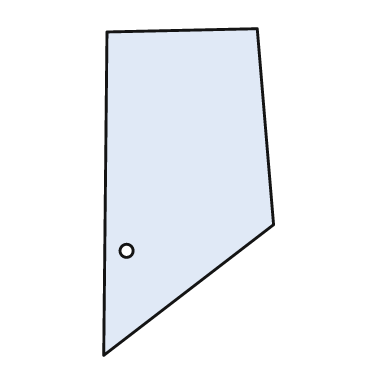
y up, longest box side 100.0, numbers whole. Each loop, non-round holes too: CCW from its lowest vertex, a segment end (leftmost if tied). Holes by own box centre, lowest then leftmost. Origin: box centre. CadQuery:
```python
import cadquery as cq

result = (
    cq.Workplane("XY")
    .moveTo(-26.0, -50.0)
    .lineTo(26.0, -10.0)
    .lineTo(21.0, 50.0)
    .lineTo(-25.0, 49.0)
    .close()
    .moveTo(-19.0, -18.0)
    .circle(2.0)
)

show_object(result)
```